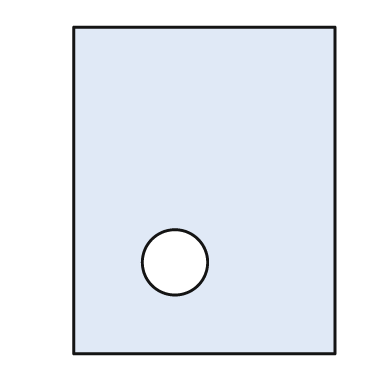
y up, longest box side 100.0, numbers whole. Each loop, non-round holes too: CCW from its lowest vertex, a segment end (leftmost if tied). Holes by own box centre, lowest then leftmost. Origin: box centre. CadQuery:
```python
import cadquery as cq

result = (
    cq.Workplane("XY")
    .moveTo(-40.0, -50.0)
    .lineTo(40.0, -50.0)
    .lineTo(40.0, 50.0)
    .lineTo(-40.0, 50.0)
    .close()
    .moveTo(-9.0, -22.0)
    .circle(10.0)
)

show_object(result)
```